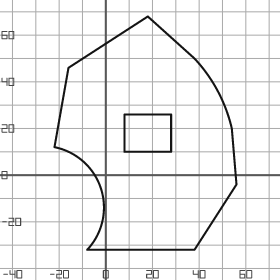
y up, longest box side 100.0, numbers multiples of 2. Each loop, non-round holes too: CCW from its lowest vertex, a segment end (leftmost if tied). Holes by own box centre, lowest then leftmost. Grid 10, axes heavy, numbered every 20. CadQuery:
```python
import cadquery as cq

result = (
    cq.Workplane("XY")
    .moveTo(-8.0, -32.0)
    .lineTo(38.0, -32.0)
    .lineTo(56.0, -4.0)
    .lineTo(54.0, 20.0)
    .threePointArc((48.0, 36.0), (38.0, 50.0))
    .lineTo(18.0, 68.0)
    .lineTo(-16.0, 46.0)
    .lineTo(-22.0, 12.0)
    .threePointArc((-2.0, -6.0), (-8.0, -32.0))
    .close()
    .moveTo(8.0, 10.0)
    .lineTo(28.0, 10.0)
    .lineTo(28.0, 26.0)
    .lineTo(8.0, 26.0)
    .close()
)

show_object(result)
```